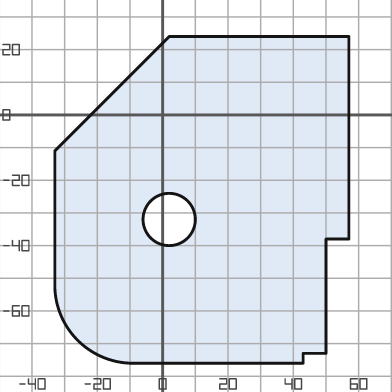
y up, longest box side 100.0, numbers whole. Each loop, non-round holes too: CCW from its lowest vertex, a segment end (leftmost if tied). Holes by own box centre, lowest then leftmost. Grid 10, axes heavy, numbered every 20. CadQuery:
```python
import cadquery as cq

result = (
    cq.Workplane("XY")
    .moveTo(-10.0, -76.0)
    .lineTo(43.0, -76.0)
    .lineTo(43.0, -73.0)
    .lineTo(50.0, -73.0)
    .lineTo(50.0, -38.0)
    .lineTo(57.0, -38.0)
    .lineTo(57.0, 24.0)
    .lineTo(2.0, 24.0)
    .lineTo(-33.0, -11.0)
    .lineTo(-33.0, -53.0)
    .threePointArc((-26.0, -69.0), (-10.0, -76.0))
    .close()
    .moveTo(2.0, -32.0)
    .circle(8.0)
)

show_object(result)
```